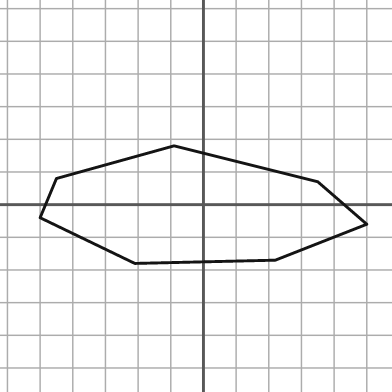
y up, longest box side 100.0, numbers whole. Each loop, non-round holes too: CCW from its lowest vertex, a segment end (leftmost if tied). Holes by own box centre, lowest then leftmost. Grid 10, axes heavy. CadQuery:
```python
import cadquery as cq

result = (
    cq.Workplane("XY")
    .moveTo(-21.0, -18.0)
    .lineTo(22.0, -17.0)
    .lineTo(50.0, -6.0)
    .lineTo(35.0, 7.0)
    .lineTo(-9.0, 18.0)
    .lineTo(-45.0, 8.0)
    .lineTo(-50.0, -4.0)
    .close()
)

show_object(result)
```